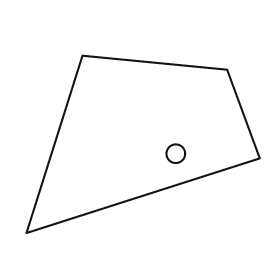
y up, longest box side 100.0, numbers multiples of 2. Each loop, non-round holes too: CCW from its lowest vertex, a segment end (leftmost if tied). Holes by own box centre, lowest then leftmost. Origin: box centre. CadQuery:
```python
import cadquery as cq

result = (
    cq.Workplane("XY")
    .moveTo(-50.0, -38.0)
    .lineTo(50.0, -6.0)
    .lineTo(36.0, 32.0)
    .lineTo(-26.0, 38.0)
    .close()
    .moveTo(14.0, -4.0)
    .circle(4.0)
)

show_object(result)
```